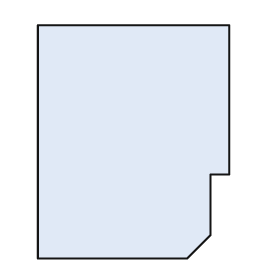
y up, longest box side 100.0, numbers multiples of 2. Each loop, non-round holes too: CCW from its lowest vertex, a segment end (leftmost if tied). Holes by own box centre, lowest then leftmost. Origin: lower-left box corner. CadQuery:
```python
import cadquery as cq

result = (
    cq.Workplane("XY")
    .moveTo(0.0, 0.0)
    .lineTo(64.0, 0.0)
    .lineTo(74.0, 10.0)
    .lineTo(74.0, 36.0)
    .lineTo(82.0, 36.0)
    .lineTo(82.0, 100.0)
    .lineTo(0.0, 100.0)
    .close()
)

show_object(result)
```